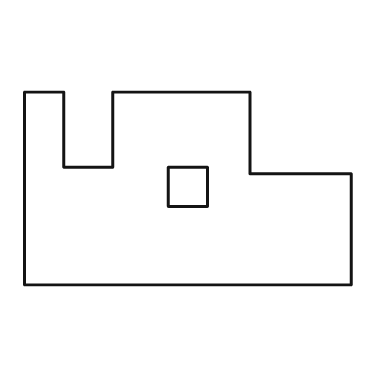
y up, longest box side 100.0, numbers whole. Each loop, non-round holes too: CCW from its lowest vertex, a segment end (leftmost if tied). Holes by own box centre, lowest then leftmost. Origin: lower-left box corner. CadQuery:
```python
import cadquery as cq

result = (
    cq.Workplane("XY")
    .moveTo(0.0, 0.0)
    .lineTo(100.0, 0.0)
    .lineTo(100.0, 34.0)
    .lineTo(69.0, 34.0)
    .lineTo(69.0, 59.0)
    .lineTo(27.0, 59.0)
    .lineTo(27.0, 36.0)
    .lineTo(12.0, 36.0)
    .lineTo(12.0, 59.0)
    .lineTo(0.0, 59.0)
    .close()
    .moveTo(44.0, 24.0)
    .lineTo(56.0, 24.0)
    .lineTo(56.0, 36.0)
    .lineTo(44.0, 36.0)
    .close()
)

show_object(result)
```